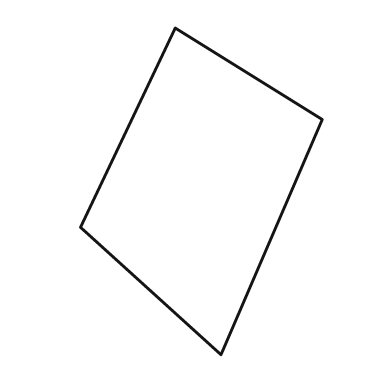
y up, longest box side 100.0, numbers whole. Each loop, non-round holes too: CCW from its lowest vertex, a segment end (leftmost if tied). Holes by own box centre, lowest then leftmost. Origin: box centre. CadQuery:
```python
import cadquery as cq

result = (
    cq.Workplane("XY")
    .moveTo(6.0, -50.0)
    .lineTo(37.0, 22.0)
    .lineTo(-8.0, 50.0)
    .lineTo(-37.0, -11.0)
    .close()
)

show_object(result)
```